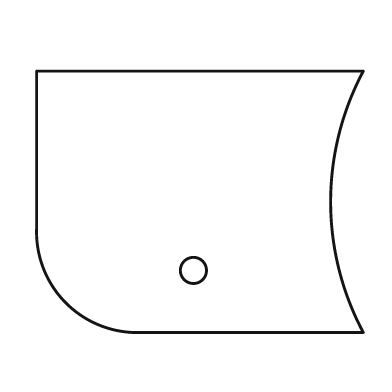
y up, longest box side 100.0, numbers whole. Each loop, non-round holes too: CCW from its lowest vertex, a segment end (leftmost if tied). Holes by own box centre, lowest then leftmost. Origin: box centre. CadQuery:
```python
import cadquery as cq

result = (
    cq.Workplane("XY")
    .moveTo(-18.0, -40.0)
    .lineTo(50.0, -40.0)
    .threePointArc((40.0, 0.0), (50.0, 40.0))
    .lineTo(-50.0, 40.0)
    .lineTo(-50.0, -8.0)
    .threePointArc((-41.0, -31.0), (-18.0, -40.0))
    .close()
    .moveTo(-2.0, -21.0)
    .circle(4.0)
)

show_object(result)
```